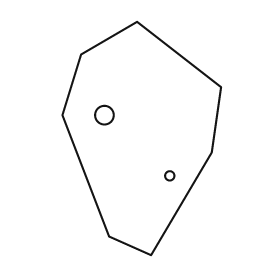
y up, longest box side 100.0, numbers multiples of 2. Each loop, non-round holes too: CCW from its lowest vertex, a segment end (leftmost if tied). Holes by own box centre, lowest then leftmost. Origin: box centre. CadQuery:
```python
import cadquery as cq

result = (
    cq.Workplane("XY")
    .moveTo(4.0, -50.0)
    .lineTo(30.0, -6.0)
    .lineTo(34.0, 22.0)
    .lineTo(-2.0, 50.0)
    .lineTo(-26.0, 36.0)
    .lineTo(-34.0, 10.0)
    .lineTo(-14.0, -42.0)
    .close()
    .moveTo(12.0, -16.0)
    .circle(2.0)
    .moveTo(-16.0, 10.0)
    .circle(4.0)
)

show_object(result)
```